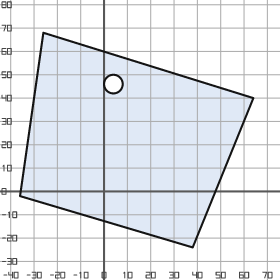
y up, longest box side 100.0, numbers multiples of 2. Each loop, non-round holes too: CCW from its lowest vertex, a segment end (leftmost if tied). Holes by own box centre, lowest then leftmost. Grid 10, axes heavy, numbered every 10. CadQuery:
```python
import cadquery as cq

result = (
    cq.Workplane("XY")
    .moveTo(38.0, -24.0)
    .lineTo(64.0, 40.0)
    .lineTo(-26.0, 68.0)
    .lineTo(-36.0, -2.0)
    .close()
    .moveTo(4.0, 46.0)
    .circle(4.0)
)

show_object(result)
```